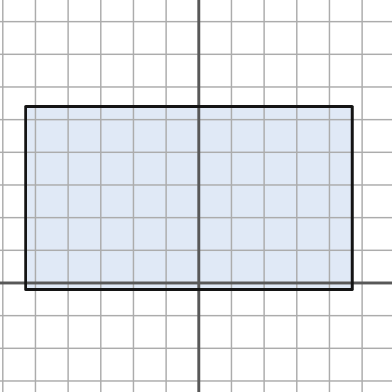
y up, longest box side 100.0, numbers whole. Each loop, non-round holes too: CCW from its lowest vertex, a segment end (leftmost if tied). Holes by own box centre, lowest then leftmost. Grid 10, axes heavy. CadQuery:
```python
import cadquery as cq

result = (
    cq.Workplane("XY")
    .moveTo(-53.0, -2.0)
    .lineTo(47.0, -2.0)
    .lineTo(47.0, 54.0)
    .lineTo(-53.0, 54.0)
    .close()
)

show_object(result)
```